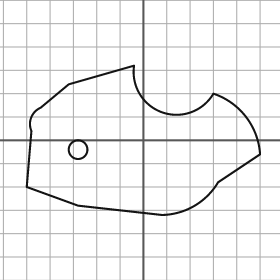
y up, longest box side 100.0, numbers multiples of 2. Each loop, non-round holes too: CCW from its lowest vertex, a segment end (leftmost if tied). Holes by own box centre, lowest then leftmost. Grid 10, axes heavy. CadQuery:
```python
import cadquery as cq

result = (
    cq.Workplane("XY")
    .moveTo(8.0, -32.0)
    .threePointArc((22.0, -28.0), (32.0, -18.0))
    .lineTo(50.0, -6.0)
    .threePointArc((44.0, 10.0), (30.0, 20.0))
    .threePointArc((8.0, 12.0), (-4.0, 32.0))
    .lineTo(-32.0, 24.0)
    .lineTo(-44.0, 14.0)
    .threePointArc((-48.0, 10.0), (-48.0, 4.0))
    .lineTo(-50.0, -20.0)
    .lineTo(-28.0, -28.0)
    .close()
    .moveTo(-28.0, -4.0)
    .circle(4.0)
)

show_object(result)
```